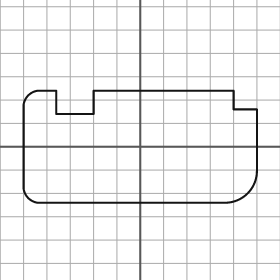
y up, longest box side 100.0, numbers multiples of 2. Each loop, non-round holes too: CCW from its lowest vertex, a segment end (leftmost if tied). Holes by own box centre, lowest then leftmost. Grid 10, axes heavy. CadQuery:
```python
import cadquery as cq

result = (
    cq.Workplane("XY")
    .moveTo(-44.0, -24.0)
    .lineTo(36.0, -24.0)
    .threePointArc((46.0, -20.0), (50.0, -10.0))
    .lineTo(50.0, 16.0)
    .lineTo(40.0, 16.0)
    .lineTo(40.0, 24.0)
    .lineTo(-20.0, 24.0)
    .lineTo(-20.0, 14.0)
    .lineTo(-36.0, 14.0)
    .lineTo(-36.0, 24.0)
    .lineTo(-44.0, 24.0)
    .threePointArc((-48.0, 22.0), (-50.0, 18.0))
    .lineTo(-50.0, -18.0)
    .threePointArc((-48.0, -22.0), (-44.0, -24.0))
    .close()
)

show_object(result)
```